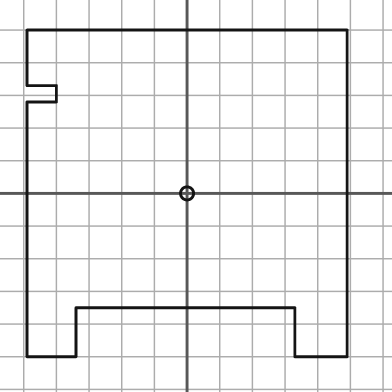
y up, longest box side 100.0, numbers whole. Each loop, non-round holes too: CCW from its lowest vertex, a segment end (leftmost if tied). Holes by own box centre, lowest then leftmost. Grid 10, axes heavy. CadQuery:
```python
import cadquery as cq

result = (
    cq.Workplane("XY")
    .moveTo(-49.0, -50.0)
    .lineTo(-34.0, -50.0)
    .lineTo(-34.0, -35.0)
    .lineTo(33.0, -35.0)
    .lineTo(33.0, -50.0)
    .lineTo(49.0, -50.0)
    .lineTo(49.0, 50.0)
    .lineTo(-49.0, 50.0)
    .lineTo(-49.0, 33.0)
    .lineTo(-40.0, 33.0)
    .lineTo(-40.0, 28.0)
    .lineTo(-49.0, 28.0)
    .close()
    .moveTo(0.0, 0.0)
    .circle(2.0)
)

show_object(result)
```